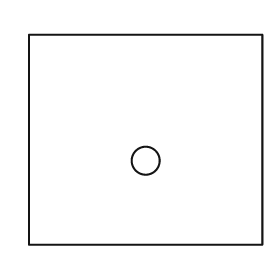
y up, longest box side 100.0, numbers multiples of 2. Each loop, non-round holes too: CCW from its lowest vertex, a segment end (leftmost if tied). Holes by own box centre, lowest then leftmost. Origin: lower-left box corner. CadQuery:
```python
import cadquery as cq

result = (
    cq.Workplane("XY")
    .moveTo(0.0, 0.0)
    .lineTo(100.0, 0.0)
    .lineTo(100.0, 90.0)
    .lineTo(0.0, 90.0)
    .close()
    .moveTo(50.0, 36.0)
    .circle(6.0)
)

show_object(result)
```